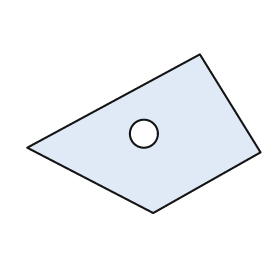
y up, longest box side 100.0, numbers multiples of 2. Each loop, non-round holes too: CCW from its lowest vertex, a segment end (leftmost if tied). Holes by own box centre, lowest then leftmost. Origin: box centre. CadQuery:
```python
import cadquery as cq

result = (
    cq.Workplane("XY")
    .moveTo(4.0, -34.0)
    .lineTo(50.0, -8.0)
    .lineTo(24.0, 34.0)
    .lineTo(-50.0, -6.0)
    .close()
    .moveTo(0.0, 0.0)
    .circle(6.0)
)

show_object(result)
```